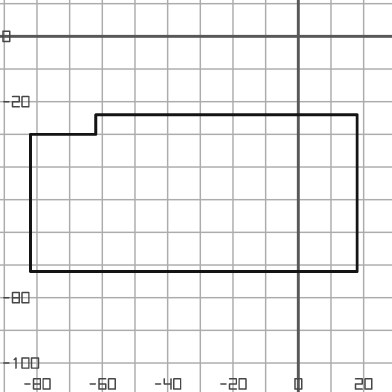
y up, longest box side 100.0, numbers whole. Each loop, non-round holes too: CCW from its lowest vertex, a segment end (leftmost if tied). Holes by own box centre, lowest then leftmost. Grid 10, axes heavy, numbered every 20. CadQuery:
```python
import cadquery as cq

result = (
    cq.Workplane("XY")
    .moveTo(-82.0, -72.0)
    .lineTo(18.0, -72.0)
    .lineTo(18.0, -24.0)
    .lineTo(-62.0, -24.0)
    .lineTo(-62.0, -30.0)
    .lineTo(-82.0, -30.0)
    .close()
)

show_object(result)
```